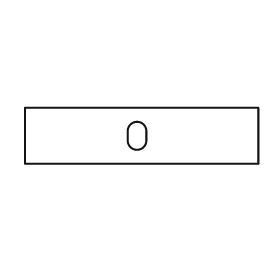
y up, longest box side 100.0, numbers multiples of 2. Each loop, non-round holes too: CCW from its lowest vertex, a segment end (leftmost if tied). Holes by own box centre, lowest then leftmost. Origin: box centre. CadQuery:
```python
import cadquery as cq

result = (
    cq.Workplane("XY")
    .moveTo(-50.0, -12.0)
    .lineTo(50.0, -12.0)
    .lineTo(50.0, 12.0)
    .lineTo(-50.0, 12.0)
    .close()
    .moveTo(-6.0, -2.0)
    .threePointArc((-2.0, -6.0), (2.0, -2.0))
    .lineTo(2.0, 2.0)
    .threePointArc((-2.0, 6.0), (-6.0, 2.0))
    .close()
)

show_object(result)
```